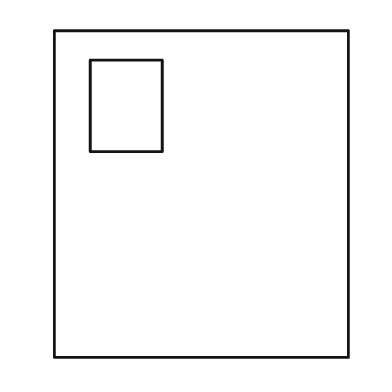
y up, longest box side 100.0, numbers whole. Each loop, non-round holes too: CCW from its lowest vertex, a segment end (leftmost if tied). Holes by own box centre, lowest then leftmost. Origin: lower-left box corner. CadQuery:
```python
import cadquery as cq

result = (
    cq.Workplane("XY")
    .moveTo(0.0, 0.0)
    .lineTo(90.0, 0.0)
    .lineTo(90.0, 100.0)
    .lineTo(0.0, 100.0)
    .close()
    .moveTo(11.0, 63.0)
    .lineTo(33.0, 63.0)
    .lineTo(33.0, 91.0)
    .lineTo(11.0, 91.0)
    .close()
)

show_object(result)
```